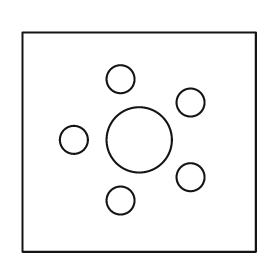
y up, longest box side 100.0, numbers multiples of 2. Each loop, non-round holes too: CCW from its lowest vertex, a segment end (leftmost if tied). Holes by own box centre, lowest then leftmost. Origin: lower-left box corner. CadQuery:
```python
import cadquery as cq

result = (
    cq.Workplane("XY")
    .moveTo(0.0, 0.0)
    .lineTo(100.0, 0.0)
    .lineTo(100.0, 94.0)
    .lineTo(0.0, 94.0)
    .close()
    .moveTo(42.0, 22.0)
    .circle(6.0)
    .moveTo(72.0, 32.0)
    .circle(6.0)
    .moveTo(22.0, 48.0)
    .circle(6.0)
    .moveTo(50.0, 48.0)
    .circle(14.0)
    .moveTo(72.0, 64.0)
    .circle(6.0)
    .moveTo(42.0, 74.0)
    .circle(6.0)
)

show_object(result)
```